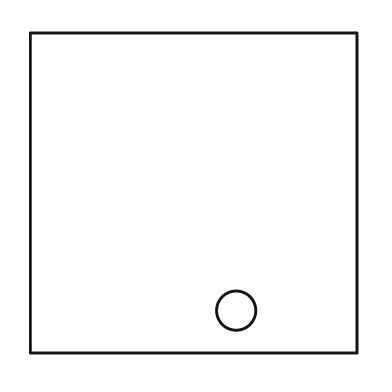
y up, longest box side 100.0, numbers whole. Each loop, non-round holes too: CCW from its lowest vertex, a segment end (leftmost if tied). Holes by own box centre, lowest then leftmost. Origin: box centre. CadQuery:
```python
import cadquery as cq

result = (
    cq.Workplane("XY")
    .moveTo(-50.0, -49.0)
    .lineTo(50.0, -49.0)
    .lineTo(50.0, 49.0)
    .lineTo(-50.0, 49.0)
    .close()
    .moveTo(13.0, -36.0)
    .circle(6.0)
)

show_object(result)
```